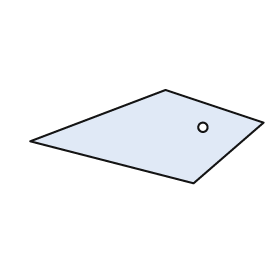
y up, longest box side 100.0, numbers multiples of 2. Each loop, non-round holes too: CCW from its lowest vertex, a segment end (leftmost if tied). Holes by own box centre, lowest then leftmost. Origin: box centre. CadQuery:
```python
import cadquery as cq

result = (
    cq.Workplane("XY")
    .moveTo(20.0, -20.0)
    .lineTo(50.0, 6.0)
    .lineTo(8.0, 20.0)
    .lineTo(-50.0, -2.0)
    .close()
    .moveTo(24.0, 4.0)
    .circle(2.0)
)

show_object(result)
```